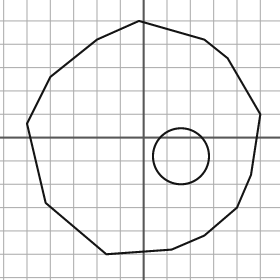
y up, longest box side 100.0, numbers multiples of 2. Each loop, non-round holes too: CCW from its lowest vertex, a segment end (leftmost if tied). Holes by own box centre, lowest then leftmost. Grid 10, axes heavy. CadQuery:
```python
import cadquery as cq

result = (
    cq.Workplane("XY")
    .moveTo(-16.0, -50.0)
    .lineTo(12.0, -48.0)
    .lineTo(26.0, -42.0)
    .lineTo(40.0, -30.0)
    .lineTo(46.0, -16.0)
    .lineTo(50.0, 10.0)
    .lineTo(36.0, 34.0)
    .lineTo(26.0, 42.0)
    .lineTo(-2.0, 50.0)
    .lineTo(-20.0, 42.0)
    .lineTo(-40.0, 26.0)
    .lineTo(-50.0, 6.0)
    .lineTo(-42.0, -28.0)
    .close()
    .moveTo(16.0, -8.0)
    .circle(12.0)
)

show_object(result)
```